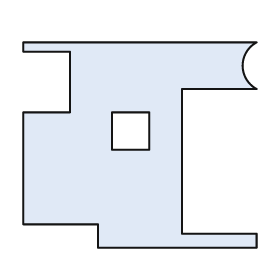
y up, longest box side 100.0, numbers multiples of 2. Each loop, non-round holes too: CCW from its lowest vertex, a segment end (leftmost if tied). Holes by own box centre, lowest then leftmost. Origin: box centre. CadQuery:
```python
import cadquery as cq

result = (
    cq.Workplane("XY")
    .moveTo(-18.0, -44.0)
    .lineTo(50.0, -44.0)
    .lineTo(50.0, -38.0)
    .lineTo(18.0, -38.0)
    .lineTo(18.0, 24.0)
    .lineTo(50.0, 24.0)
    .threePointArc((44.0, 34.0), (50.0, 44.0))
    .lineTo(-50.0, 44.0)
    .lineTo(-50.0, 40.0)
    .lineTo(-30.0, 40.0)
    .lineTo(-30.0, 14.0)
    .lineTo(-50.0, 14.0)
    .lineTo(-50.0, -34.0)
    .lineTo(-18.0, -34.0)
    .close()
    .moveTo(-12.0, -2.0)
    .lineTo(4.0, -2.0)
    .lineTo(4.0, 14.0)
    .lineTo(-12.0, 14.0)
    .close()
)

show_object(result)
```